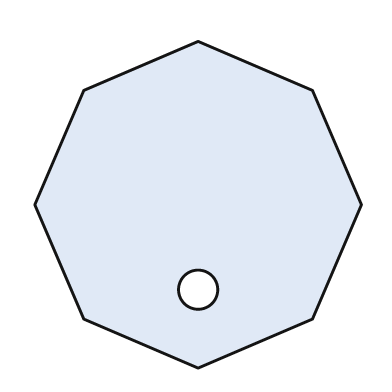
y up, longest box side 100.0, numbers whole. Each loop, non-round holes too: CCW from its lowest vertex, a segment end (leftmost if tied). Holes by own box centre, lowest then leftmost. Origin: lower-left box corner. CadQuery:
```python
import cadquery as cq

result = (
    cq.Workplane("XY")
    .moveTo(50.0, 0.0)
    .lineTo(85.0, 15.0)
    .lineTo(100.0, 50.0)
    .lineTo(85.0, 85.0)
    .lineTo(50.0, 100.0)
    .lineTo(15.0, 85.0)
    .lineTo(0.0, 50.0)
    .lineTo(15.0, 15.0)
    .close()
    .moveTo(50.0, 24.0)
    .circle(6.0)
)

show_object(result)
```